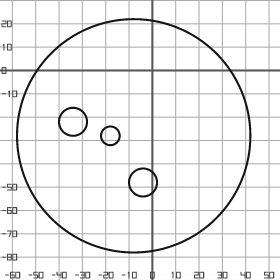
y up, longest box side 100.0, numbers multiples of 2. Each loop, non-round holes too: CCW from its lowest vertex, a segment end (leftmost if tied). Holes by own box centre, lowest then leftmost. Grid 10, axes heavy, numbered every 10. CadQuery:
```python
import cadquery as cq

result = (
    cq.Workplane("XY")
    .moveTo(-8.0, -28.0)
    .circle(50.0)
    .moveTo(-4.0, -48.0)
    .circle(6.0)
    .moveTo(-18.0, -28.0)
    .circle(4.0)
    .moveTo(-34.0, -22.0)
    .circle(6.0)
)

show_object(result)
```